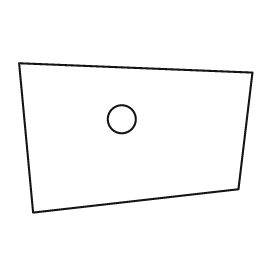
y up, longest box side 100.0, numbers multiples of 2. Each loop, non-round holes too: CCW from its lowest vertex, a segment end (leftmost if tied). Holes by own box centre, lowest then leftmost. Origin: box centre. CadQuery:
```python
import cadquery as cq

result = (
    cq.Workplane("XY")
    .moveTo(-44.0, -32.0)
    .lineTo(44.0, -22.0)
    .lineTo(50.0, 28.0)
    .lineTo(-50.0, 32.0)
    .close()
    .moveTo(-6.0, 8.0)
    .circle(6.0)
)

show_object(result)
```